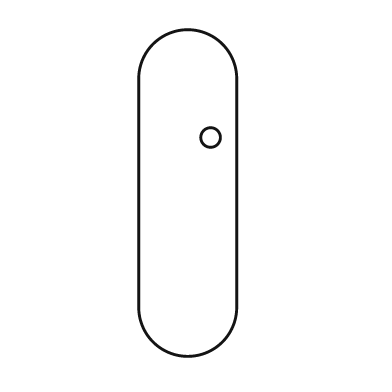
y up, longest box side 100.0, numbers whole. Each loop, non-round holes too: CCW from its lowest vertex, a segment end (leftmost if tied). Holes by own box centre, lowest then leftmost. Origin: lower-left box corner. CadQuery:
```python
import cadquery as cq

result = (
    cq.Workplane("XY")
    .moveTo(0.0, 15.0)
    .threePointArc((15.0, 0.0), (30.0, 15.0))
    .lineTo(30.0, 85.0)
    .threePointArc((15.0, 100.0), (0.0, 85.0))
    .close()
    .moveTo(22.0, 67.0)
    .circle(3.0)
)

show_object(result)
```